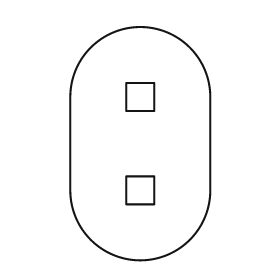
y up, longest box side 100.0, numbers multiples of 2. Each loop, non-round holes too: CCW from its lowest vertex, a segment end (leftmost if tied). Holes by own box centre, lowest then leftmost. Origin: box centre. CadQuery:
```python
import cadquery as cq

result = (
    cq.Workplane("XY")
    .moveTo(-30.0, -20.0)
    .threePointArc((0.0, -50.0), (30.0, -20.0))
    .lineTo(30.0, 20.0)
    .threePointArc((0.0, 50.0), (-30.0, 20.0))
    .close()
    .moveTo(-6.0, -26.0)
    .lineTo(6.0, -26.0)
    .lineTo(6.0, -14.0)
    .lineTo(-6.0, -14.0)
    .close()
    .moveTo(-6.0, 14.0)
    .lineTo(6.0, 14.0)
    .lineTo(6.0, 26.0)
    .lineTo(-6.0, 26.0)
    .close()
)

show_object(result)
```